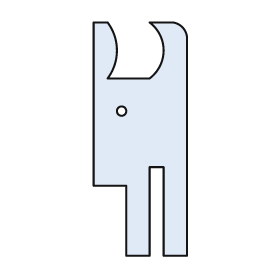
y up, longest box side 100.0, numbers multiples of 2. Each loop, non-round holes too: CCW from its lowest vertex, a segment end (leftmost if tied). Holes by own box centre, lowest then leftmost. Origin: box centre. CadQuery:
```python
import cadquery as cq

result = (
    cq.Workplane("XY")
    .moveTo(-6.0, -50.0)
    .lineTo(4.0, -50.0)
    .lineTo(4.0, -12.0)
    .lineTo(10.0, -12.0)
    .lineTo(10.0, -50.0)
    .lineTo(20.0, -50.0)
    .lineTo(20.0, 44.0)
    .threePointArc((18.0, 48.0), (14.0, 50.0))
    .lineTo(4.0, 50.0)
    .threePointArc((10.0, 38.0), (4.0, 26.0))
    .lineTo(-14.0, 26.0)
    .threePointArc((-10.0, 38.0), (-14.0, 50.0))
    .lineTo(-20.0, 50.0)
    .lineTo(-20.0, -20.0)
    .lineTo(-6.0, -20.0)
    .close()
    .moveTo(-8.0, 12.0)
    .circle(2.0)
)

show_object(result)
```